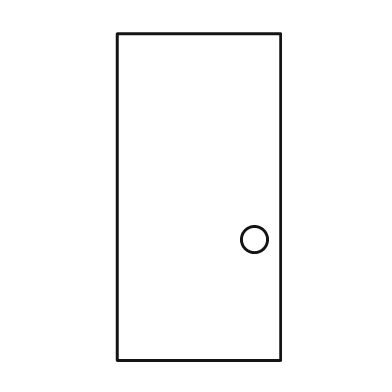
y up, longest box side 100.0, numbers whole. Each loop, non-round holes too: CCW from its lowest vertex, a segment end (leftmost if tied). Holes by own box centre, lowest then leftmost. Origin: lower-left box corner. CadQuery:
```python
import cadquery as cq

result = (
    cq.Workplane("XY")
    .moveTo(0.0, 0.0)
    .lineTo(50.0, 0.0)
    .lineTo(50.0, 100.0)
    .lineTo(0.0, 100.0)
    .close()
    .moveTo(42.0, 37.0)
    .circle(4.0)
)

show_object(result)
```